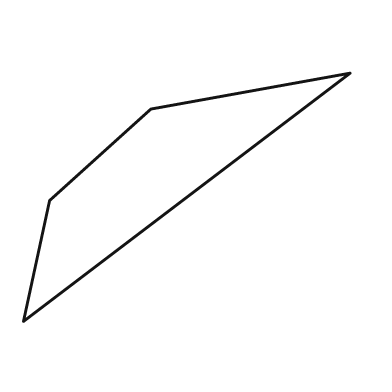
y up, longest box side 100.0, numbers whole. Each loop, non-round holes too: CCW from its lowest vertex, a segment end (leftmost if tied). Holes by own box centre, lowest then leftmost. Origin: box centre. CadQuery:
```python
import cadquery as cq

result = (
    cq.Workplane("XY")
    .moveTo(-50.0, -38.0)
    .lineTo(50.0, 38.0)
    .lineTo(-11.0, 27.0)
    .lineTo(-42.0, -1.0)
    .close()
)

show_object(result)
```